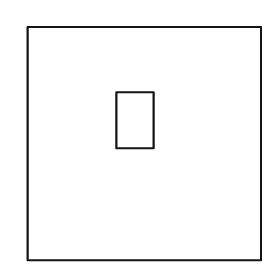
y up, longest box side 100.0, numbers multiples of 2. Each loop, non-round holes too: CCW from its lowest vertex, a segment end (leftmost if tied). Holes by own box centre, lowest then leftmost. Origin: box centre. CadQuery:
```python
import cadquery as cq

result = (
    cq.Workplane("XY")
    .moveTo(-50.0, -50.0)
    .lineTo(50.0, -50.0)
    .lineTo(50.0, 50.0)
    .lineTo(-50.0, 50.0)
    .close()
    .moveTo(-12.0, -2.0)
    .lineTo(4.0, -2.0)
    .lineTo(4.0, 22.0)
    .lineTo(-12.0, 22.0)
    .close()
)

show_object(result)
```